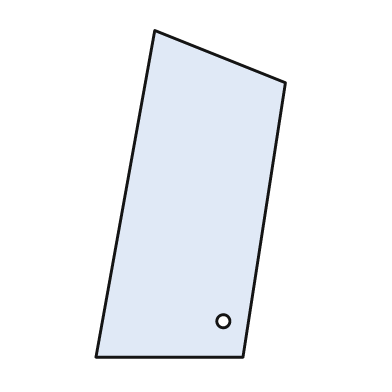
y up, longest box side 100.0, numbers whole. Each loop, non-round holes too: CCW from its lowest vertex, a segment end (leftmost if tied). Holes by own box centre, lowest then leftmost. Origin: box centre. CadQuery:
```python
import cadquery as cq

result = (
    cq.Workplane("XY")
    .moveTo(-29.0, -50.0)
    .lineTo(16.0, -50.0)
    .lineTo(29.0, 34.0)
    .lineTo(-11.0, 50.0)
    .close()
    .moveTo(10.0, -39.0)
    .circle(2.0)
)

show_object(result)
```